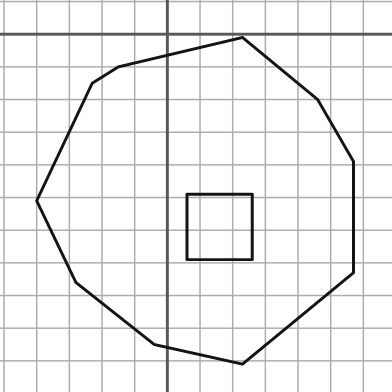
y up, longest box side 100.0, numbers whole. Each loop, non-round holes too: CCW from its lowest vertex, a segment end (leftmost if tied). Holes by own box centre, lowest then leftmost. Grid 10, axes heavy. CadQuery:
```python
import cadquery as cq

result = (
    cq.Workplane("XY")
    .moveTo(23.0, -101.0)
    .lineTo(57.0, -73.0)
    .lineTo(57.0, -39.0)
    .lineTo(46.0, -20.0)
    .lineTo(23.0, -1.0)
    .lineTo(-15.0, -10.0)
    .lineTo(-23.0, -15.0)
    .lineTo(-40.0, -51.0)
    .lineTo(-28.0, -76.0)
    .lineTo(-4.0, -95.0)
    .close()
    .moveTo(6.0, -69.0)
    .lineTo(26.0, -69.0)
    .lineTo(26.0, -49.0)
    .lineTo(6.0, -49.0)
    .close()
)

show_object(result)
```